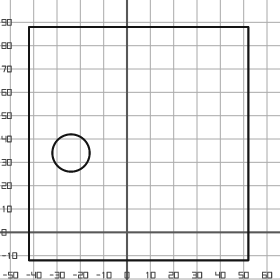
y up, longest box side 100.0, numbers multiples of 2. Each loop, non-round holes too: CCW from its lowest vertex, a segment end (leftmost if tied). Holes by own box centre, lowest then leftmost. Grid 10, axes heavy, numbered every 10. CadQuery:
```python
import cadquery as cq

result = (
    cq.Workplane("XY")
    .moveTo(-42.0, -12.0)
    .lineTo(52.0, -12.0)
    .lineTo(52.0, 88.0)
    .lineTo(-42.0, 88.0)
    .close()
    .moveTo(-24.0, 34.0)
    .circle(8.0)
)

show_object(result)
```